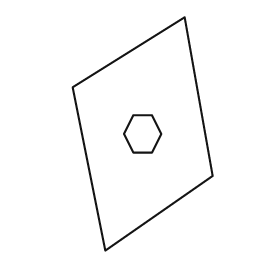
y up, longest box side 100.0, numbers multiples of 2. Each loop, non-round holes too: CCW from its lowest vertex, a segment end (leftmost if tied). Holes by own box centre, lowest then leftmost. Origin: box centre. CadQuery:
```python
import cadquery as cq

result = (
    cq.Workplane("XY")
    .moveTo(-16.0, -50.0)
    .lineTo(30.0, -18.0)
    .lineTo(18.0, 50.0)
    .lineTo(-30.0, 20.0)
    .close()
    .moveTo(-4.0, -8.0)
    .lineTo(4.0, -8.0)
    .lineTo(8.0, 0.0)
    .lineTo(4.0, 8.0)
    .lineTo(-4.0, 8.0)
    .lineTo(-8.0, 0.0)
    .close()
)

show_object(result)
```